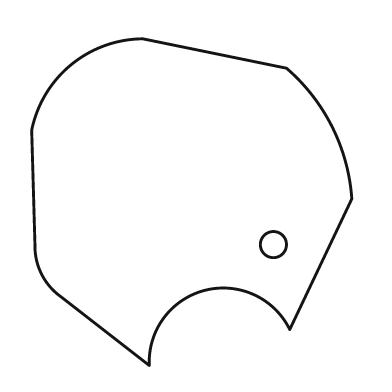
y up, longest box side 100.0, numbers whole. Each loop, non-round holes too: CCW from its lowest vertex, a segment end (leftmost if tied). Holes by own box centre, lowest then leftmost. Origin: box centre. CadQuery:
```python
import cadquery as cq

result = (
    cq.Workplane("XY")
    .moveTo(-13.0, -50.0)
    .threePointArc((4.0, -27.0), (30.0, -39.0))
    .lineTo(49.0, 1.0)
    .threePointArc((43.0, 23.0), (29.0, 41.0))
    .lineTo(-15.0, 50.0)
    .threePointArc((-37.0, 42.0), (-49.0, 22.0))
    .lineTo(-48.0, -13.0)
    .threePointArc((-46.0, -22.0), (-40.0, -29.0))
    .close()
    .moveTo(25.0, -13.0)
    .circle(4.0)
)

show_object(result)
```